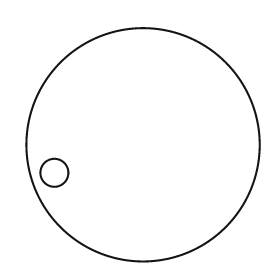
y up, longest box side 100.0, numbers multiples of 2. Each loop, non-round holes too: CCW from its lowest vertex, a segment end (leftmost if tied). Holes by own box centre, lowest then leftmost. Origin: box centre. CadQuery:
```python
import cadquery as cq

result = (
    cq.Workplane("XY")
    .moveTo(0.0, 0.0)
    .circle(50.0)
    .moveTo(-38.0, -12.0)
    .circle(6.0)
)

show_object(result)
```